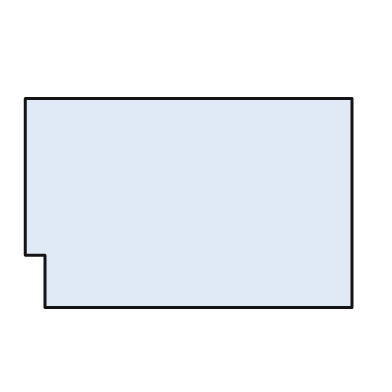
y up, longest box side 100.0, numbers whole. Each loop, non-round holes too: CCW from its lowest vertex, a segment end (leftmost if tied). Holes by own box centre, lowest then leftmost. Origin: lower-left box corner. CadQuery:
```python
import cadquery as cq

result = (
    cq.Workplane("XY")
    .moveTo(6.0, 0.0)
    .lineTo(100.0, 0.0)
    .lineTo(100.0, 64.0)
    .lineTo(0.0, 64.0)
    .lineTo(0.0, 16.0)
    .lineTo(6.0, 16.0)
    .close()
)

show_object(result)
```